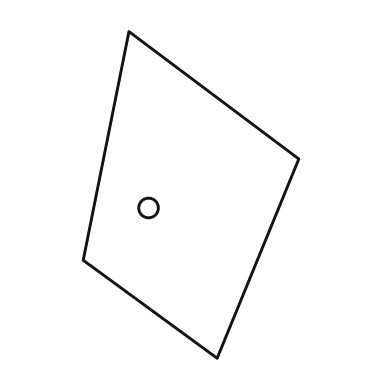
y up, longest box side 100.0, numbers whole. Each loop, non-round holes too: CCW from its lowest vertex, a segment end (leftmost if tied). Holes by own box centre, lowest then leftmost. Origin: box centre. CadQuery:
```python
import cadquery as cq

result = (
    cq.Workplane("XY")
    .moveTo(8.0, -50.0)
    .lineTo(33.0, 11.0)
    .lineTo(-19.0, 50.0)
    .lineTo(-33.0, -20.0)
    .close()
    .moveTo(-13.0, -4.0)
    .circle(3.0)
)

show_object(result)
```